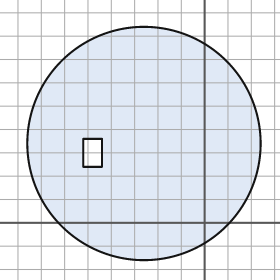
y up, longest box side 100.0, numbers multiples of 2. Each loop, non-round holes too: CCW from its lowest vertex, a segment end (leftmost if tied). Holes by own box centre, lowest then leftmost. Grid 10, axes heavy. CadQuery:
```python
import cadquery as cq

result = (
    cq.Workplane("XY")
    .moveTo(-26.0, 34.0)
    .circle(50.0)
    .moveTo(-52.0, 24.0)
    .lineTo(-44.0, 24.0)
    .lineTo(-44.0, 36.0)
    .lineTo(-52.0, 36.0)
    .close()
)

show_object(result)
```